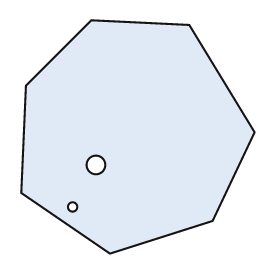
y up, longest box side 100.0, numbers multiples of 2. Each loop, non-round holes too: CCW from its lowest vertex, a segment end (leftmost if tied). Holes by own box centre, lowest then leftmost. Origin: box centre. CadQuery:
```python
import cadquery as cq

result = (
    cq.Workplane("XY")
    .moveTo(-12.0, -50.0)
    .lineTo(32.0, -36.0)
    .lineTo(50.0, 2.0)
    .lineTo(22.0, 48.0)
    .lineTo(-20.0, 50.0)
    .lineTo(-48.0, 22.0)
    .lineTo(-50.0, -24.0)
    .close()
    .moveTo(-28.0, -30.0)
    .circle(2.0)
    .moveTo(-18.0, -12.0)
    .circle(4.0)
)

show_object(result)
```